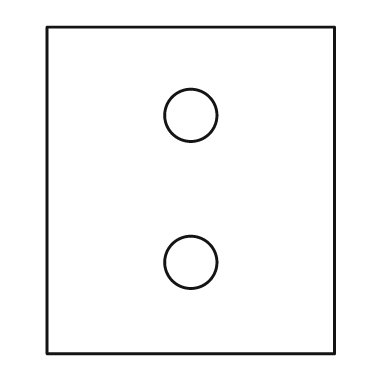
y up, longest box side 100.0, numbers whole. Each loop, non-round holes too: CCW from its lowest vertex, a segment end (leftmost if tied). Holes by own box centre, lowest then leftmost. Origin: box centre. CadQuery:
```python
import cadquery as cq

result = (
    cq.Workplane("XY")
    .moveTo(-44.0, -50.0)
    .lineTo(44.0, -50.0)
    .lineTo(44.0, 50.0)
    .lineTo(-44.0, 50.0)
    .close()
    .moveTo(0.0, -22.0)
    .circle(8.0)
    .moveTo(0.0, 23.0)
    .circle(8.0)
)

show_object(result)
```